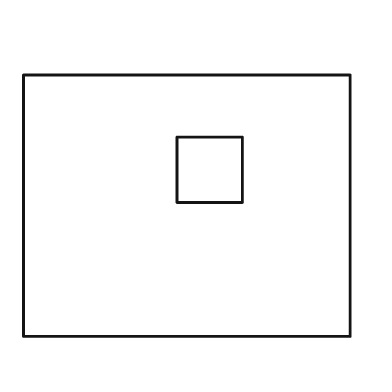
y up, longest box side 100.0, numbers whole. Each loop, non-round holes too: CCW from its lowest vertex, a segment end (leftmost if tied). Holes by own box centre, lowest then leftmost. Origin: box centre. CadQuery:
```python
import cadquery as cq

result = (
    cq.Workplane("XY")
    .moveTo(-50.0, -40.0)
    .lineTo(50.0, -40.0)
    .lineTo(50.0, 40.0)
    .lineTo(-50.0, 40.0)
    .close()
    .moveTo(-3.0, 1.0)
    .lineTo(17.0, 1.0)
    .lineTo(17.0, 21.0)
    .lineTo(-3.0, 21.0)
    .close()
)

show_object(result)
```